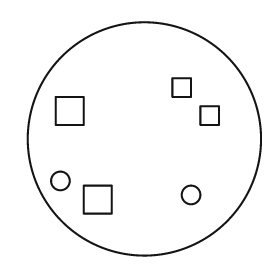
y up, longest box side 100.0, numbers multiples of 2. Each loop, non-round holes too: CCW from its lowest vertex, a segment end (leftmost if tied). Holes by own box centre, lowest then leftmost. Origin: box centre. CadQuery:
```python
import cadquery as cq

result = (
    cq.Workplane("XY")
    .moveTo(0.0, 0.0)
    .circle(50.0)
    .moveTo(-26.0, -32.0)
    .lineTo(-14.0, -32.0)
    .lineTo(-14.0, -20.0)
    .lineTo(-26.0, -20.0)
    .close()
    .moveTo(20.0, -24.0)
    .circle(4.0)
    .moveTo(-36.0, -18.0)
    .circle(4.0)
    .moveTo(24.0, 6.0)
    .lineTo(32.0, 6.0)
    .lineTo(32.0, 14.0)
    .lineTo(24.0, 14.0)
    .close()
    .moveTo(-38.0, 6.0)
    .lineTo(-26.0, 6.0)
    .lineTo(-26.0, 18.0)
    .lineTo(-38.0, 18.0)
    .close()
    .moveTo(12.0, 18.0)
    .lineTo(20.0, 18.0)
    .lineTo(20.0, 26.0)
    .lineTo(12.0, 26.0)
    .close()
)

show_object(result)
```